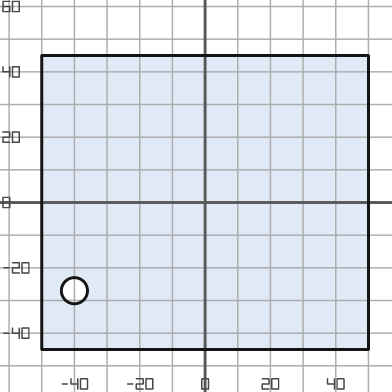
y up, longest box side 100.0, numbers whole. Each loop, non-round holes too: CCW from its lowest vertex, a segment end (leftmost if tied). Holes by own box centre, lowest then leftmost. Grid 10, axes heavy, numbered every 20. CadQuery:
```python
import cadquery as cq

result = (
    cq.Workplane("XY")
    .moveTo(-50.0, -45.0)
    .lineTo(50.0, -45.0)
    .lineTo(50.0, 45.0)
    .lineTo(-50.0, 45.0)
    .close()
    .moveTo(-40.0, -27.0)
    .circle(4.0)
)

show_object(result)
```